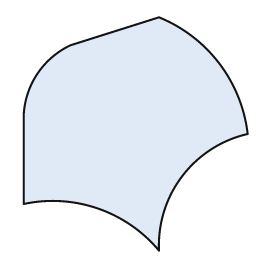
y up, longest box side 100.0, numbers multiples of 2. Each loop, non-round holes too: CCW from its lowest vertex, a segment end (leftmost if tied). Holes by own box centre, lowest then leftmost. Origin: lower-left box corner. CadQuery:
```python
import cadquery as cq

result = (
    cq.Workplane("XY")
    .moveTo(58.0, 0.0)
    .threePointArc((68.0, 32.0), (96.0, 50.0))
    .threePointArc((84.0, 80.0), (58.0, 100.0))
    .lineTo(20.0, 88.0)
    .threePointArc((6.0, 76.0), (0.0, 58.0))
    .lineTo(0.0, 20.0)
    .threePointArc((32.0, 18.0), (58.0, 0.0))
    .close()
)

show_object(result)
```